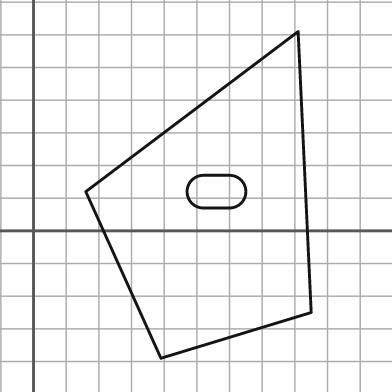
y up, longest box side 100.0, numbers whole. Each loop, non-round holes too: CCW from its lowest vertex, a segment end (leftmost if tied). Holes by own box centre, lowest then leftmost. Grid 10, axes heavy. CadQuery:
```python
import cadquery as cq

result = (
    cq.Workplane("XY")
    .moveTo(39.0, -39.0)
    .lineTo(85.0, -25.0)
    .lineTo(81.0, 61.0)
    .lineTo(16.0, 12.0)
    .close()
    .moveTo(52.0, 7.0)
    .lineTo(60.0, 7.0)
    .threePointArc((65.0, 12.0), (60.0, 17.0))
    .lineTo(52.0, 17.0)
    .threePointArc((47.0, 12.0), (52.0, 7.0))
    .close()
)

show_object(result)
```